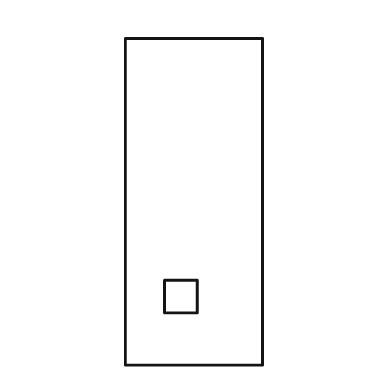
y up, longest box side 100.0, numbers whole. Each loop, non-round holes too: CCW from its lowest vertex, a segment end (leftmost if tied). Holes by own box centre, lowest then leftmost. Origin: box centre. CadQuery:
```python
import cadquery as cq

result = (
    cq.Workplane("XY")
    .moveTo(-21.0, -50.0)
    .lineTo(21.0, -50.0)
    .lineTo(21.0, 50.0)
    .lineTo(-21.0, 50.0)
    .close()
    .moveTo(-9.0, -34.0)
    .lineTo(1.0, -34.0)
    .lineTo(1.0, -24.0)
    .lineTo(-9.0, -24.0)
    .close()
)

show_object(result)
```